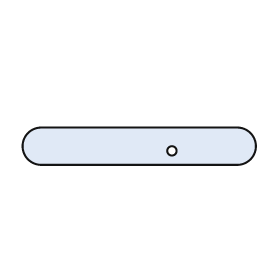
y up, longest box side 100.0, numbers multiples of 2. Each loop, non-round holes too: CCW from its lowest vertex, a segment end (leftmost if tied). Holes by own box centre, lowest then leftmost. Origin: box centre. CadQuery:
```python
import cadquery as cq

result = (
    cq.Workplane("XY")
    .moveTo(-42.0, -8.0)
    .lineTo(42.0, -8.0)
    .threePointArc((50.0, 0.0), (42.0, 8.0))
    .lineTo(-42.0, 8.0)
    .threePointArc((-50.0, 0.0), (-42.0, -8.0))
    .close()
    .moveTo(14.0, -2.0)
    .circle(2.0)
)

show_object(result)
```